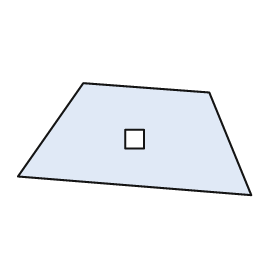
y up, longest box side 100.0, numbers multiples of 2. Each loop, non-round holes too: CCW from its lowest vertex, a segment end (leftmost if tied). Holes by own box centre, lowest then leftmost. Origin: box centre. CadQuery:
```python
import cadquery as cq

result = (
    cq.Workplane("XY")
    .moveTo(50.0, -24.0)
    .lineTo(32.0, 20.0)
    .lineTo(-22.0, 24.0)
    .lineTo(-50.0, -16.0)
    .close()
    .moveTo(-4.0, -4.0)
    .lineTo(4.0, -4.0)
    .lineTo(4.0, 4.0)
    .lineTo(-4.0, 4.0)
    .close()
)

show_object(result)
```